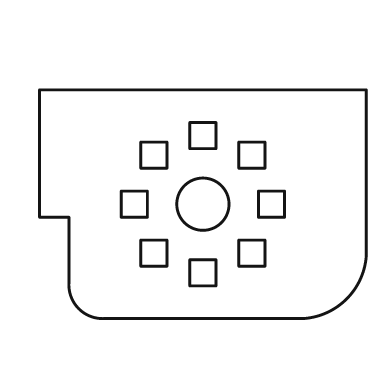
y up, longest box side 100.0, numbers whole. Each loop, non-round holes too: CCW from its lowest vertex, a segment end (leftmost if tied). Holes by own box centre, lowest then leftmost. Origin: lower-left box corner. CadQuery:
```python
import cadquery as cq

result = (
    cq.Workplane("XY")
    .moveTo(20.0, 0.0)
    .lineTo(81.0, 0.0)
    .threePointArc((94.0, 6.0), (100.0, 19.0))
    .lineTo(100.0, 70.0)
    .lineTo(0.0, 70.0)
    .lineTo(0.0, 31.0)
    .lineTo(9.0, 31.0)
    .lineTo(9.0, 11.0)
    .threePointArc((12.0, 3.0), (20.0, 0.0))
    .close()
    .moveTo(46.0, 10.0)
    .lineTo(54.0, 10.0)
    .lineTo(54.0, 18.0)
    .lineTo(46.0, 18.0)
    .close()
    .moveTo(31.0, 16.0)
    .lineTo(39.0, 16.0)
    .lineTo(39.0, 24.0)
    .lineTo(31.0, 24.0)
    .close()
    .moveTo(61.0, 16.0)
    .lineTo(69.0, 16.0)
    .lineTo(69.0, 24.0)
    .lineTo(61.0, 24.0)
    .close()
    .moveTo(25.0, 31.0)
    .lineTo(33.0, 31.0)
    .lineTo(33.0, 39.0)
    .lineTo(25.0, 39.0)
    .close()
    .moveTo(50.0, 35.0)
    .circle(8.0)
    .moveTo(67.0, 31.0)
    .lineTo(75.0, 31.0)
    .lineTo(75.0, 39.0)
    .lineTo(67.0, 39.0)
    .close()
    .moveTo(31.0, 46.0)
    .lineTo(39.0, 46.0)
    .lineTo(39.0, 54.0)
    .lineTo(31.0, 54.0)
    .close()
    .moveTo(61.0, 46.0)
    .lineTo(69.0, 46.0)
    .lineTo(69.0, 54.0)
    .lineTo(61.0, 54.0)
    .close()
    .moveTo(46.0, 52.0)
    .lineTo(54.0, 52.0)
    .lineTo(54.0, 60.0)
    .lineTo(46.0, 60.0)
    .close()
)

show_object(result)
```